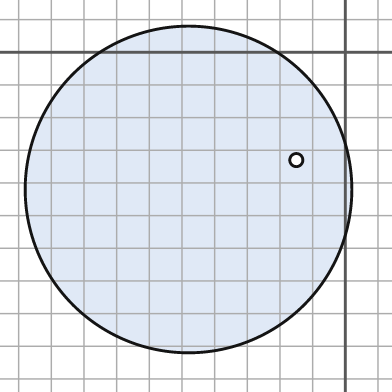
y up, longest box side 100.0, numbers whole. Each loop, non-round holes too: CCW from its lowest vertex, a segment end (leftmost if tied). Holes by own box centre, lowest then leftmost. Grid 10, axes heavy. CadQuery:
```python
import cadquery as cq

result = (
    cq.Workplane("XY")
    .moveTo(-48.0, -42.0)
    .circle(50.0)
    .moveTo(-15.0, -33.0)
    .circle(2.0)
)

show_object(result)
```